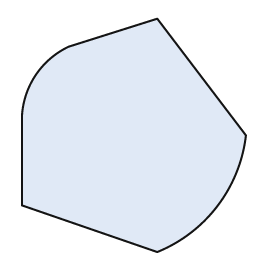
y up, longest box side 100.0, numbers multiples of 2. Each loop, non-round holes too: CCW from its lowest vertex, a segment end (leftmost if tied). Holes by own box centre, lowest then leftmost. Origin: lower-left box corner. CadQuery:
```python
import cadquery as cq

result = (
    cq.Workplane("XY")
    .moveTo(58.0, 0.0)
    .threePointArc((84.0, 20.0), (96.0, 50.0))
    .lineTo(58.0, 100.0)
    .lineTo(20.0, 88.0)
    .threePointArc((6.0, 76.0), (0.0, 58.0))
    .lineTo(0.0, 20.0)
    .close()
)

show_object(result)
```